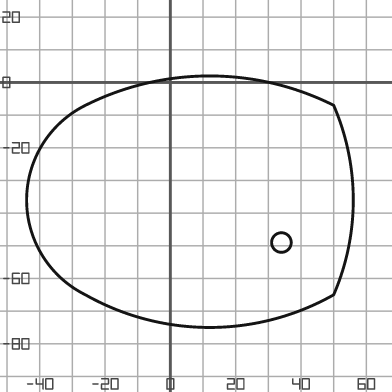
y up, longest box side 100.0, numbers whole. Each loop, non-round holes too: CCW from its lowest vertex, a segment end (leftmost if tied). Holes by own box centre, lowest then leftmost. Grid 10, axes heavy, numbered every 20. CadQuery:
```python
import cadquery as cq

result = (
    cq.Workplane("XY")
    .moveTo(-26.0, -65.0)
    .threePointArc((12.0, -75.0), (50.0, -65.0))
    .threePointArc((56.0, -36.0), (50.0, -7.0))
    .threePointArc((12.0, 2.0), (-26.0, -7.0))
    .threePointArc((-44.0, -36.0), (-26.0, -65.0))
    .close()
    .moveTo(34.0, -49.0)
    .circle(3.0)
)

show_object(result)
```